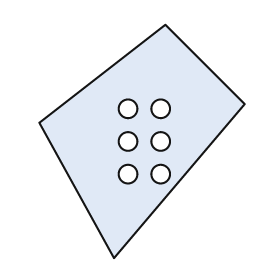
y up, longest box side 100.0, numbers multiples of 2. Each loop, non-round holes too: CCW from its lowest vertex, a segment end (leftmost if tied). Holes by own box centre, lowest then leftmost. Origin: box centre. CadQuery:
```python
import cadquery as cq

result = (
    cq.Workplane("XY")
    .moveTo(-12.0, -50.0)
    .lineTo(44.0, 16.0)
    .lineTo(10.0, 50.0)
    .lineTo(-44.0, 8.0)
    .close()
    .moveTo(-6.0, -14.0)
    .circle(4.0)
    .moveTo(8.0, -14.0)
    .circle(4.0)
    .moveTo(-6.0, 0.0)
    .circle(4.0)
    .moveTo(8.0, 0.0)
    .circle(4.0)
    .moveTo(-6.0, 14.0)
    .circle(4.0)
    .moveTo(8.0, 14.0)
    .circle(4.0)
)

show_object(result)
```